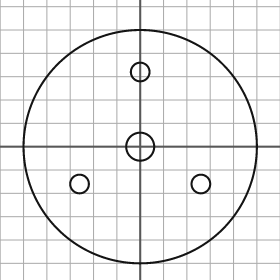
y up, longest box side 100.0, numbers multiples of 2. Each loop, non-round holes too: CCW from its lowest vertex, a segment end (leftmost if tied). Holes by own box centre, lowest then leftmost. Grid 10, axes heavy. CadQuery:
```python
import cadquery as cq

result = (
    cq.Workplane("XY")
    .moveTo(0.0, 0.0)
    .circle(50.0)
    .moveTo(-26.0, -16.0)
    .circle(4.0)
    .moveTo(26.0, -16.0)
    .circle(4.0)
    .moveTo(0.0, 0.0)
    .circle(6.0)
    .moveTo(0.0, 32.0)
    .circle(4.0)
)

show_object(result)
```